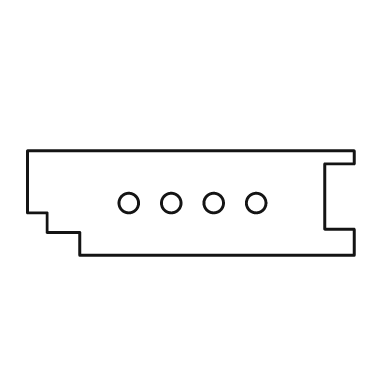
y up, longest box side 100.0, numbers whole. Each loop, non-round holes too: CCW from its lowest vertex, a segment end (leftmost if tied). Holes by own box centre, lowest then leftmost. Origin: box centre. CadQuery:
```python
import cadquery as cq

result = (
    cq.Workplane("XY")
    .moveTo(-34.0, -16.0)
    .lineTo(50.0, -16.0)
    .lineTo(50.0, -8.0)
    .lineTo(41.0, -8.0)
    .lineTo(41.0, 12.0)
    .lineTo(50.0, 12.0)
    .lineTo(50.0, 16.0)
    .lineTo(-50.0, 16.0)
    .lineTo(-50.0, -3.0)
    .lineTo(-44.0, -3.0)
    .lineTo(-44.0, -9.0)
    .lineTo(-34.0, -9.0)
    .close()
    .moveTo(-19.0, 0.0)
    .circle(3.0)
    .moveTo(-6.0, 0.0)
    .circle(3.0)
    .moveTo(7.0, 0.0)
    .circle(3.0)
    .moveTo(20.0, 0.0)
    .circle(3.0)
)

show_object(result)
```